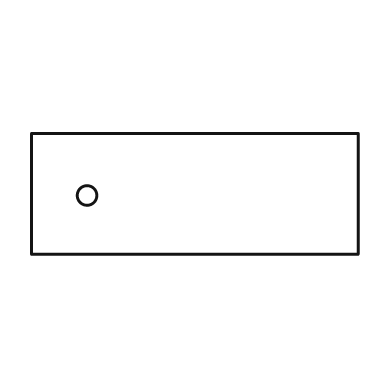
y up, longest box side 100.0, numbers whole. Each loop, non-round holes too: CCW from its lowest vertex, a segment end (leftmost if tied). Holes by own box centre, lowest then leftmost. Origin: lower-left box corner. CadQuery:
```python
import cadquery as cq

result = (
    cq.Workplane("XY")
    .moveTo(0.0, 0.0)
    .lineTo(100.0, 0.0)
    .lineTo(100.0, 37.0)
    .lineTo(0.0, 37.0)
    .close()
    .moveTo(17.0, 18.0)
    .circle(3.0)
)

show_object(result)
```